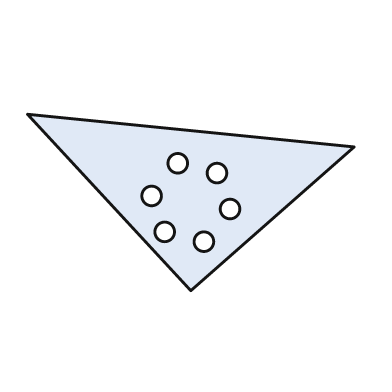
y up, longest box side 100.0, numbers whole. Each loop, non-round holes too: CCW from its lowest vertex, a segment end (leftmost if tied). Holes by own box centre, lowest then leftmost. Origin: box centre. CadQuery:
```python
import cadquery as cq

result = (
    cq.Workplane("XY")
    .moveTo(0.0, -27.0)
    .lineTo(50.0, 17.0)
    .lineTo(-50.0, 27.0)
    .close()
    .moveTo(4.0, -12.0)
    .circle(3.0)
    .moveTo(-8.0, -9.0)
    .circle(3.0)
    .moveTo(12.0, -2.0)
    .circle(3.0)
    .moveTo(-12.0, 2.0)
    .circle(3.0)
    .moveTo(8.0, 9.0)
    .circle(3.0)
    .moveTo(-4.0, 12.0)
    .circle(3.0)
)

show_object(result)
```